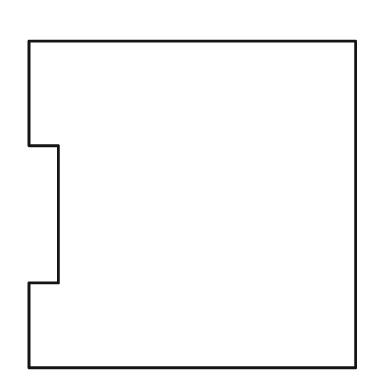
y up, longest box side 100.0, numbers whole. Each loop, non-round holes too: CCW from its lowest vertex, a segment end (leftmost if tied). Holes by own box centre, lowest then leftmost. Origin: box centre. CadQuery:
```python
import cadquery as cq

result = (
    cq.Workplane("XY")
    .moveTo(-50.0, -50.0)
    .lineTo(50.0, -50.0)
    .lineTo(50.0, 50.0)
    .lineTo(-50.0, 50.0)
    .lineTo(-50.0, 18.0)
    .lineTo(-41.0, 18.0)
    .lineTo(-41.0, -24.0)
    .lineTo(-50.0, -24.0)
    .close()
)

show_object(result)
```